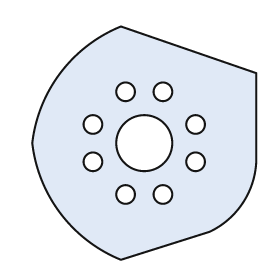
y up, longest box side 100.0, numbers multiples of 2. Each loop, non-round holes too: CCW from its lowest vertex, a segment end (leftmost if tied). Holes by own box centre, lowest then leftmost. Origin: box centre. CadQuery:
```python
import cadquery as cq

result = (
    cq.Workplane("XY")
    .moveTo(-10.0, -50.0)
    .lineTo(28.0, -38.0)
    .threePointArc((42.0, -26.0), (48.0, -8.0))
    .lineTo(48.0, 30.0)
    .lineTo(-10.0, 50.0)
    .threePointArc((-36.0, 30.0), (-48.0, 0.0))
    .threePointArc((-36.0, -30.0), (-10.0, -50.0))
    .close()
    .moveTo(-8.0, -22.0)
    .circle(4.0)
    .moveTo(8.0, -22.0)
    .circle(4.0)
    .moveTo(-22.0, -8.0)
    .circle(4.0)
    .moveTo(22.0, -8.0)
    .circle(4.0)
    .moveTo(0.0, 0.0)
    .circle(12.0)
    .moveTo(-22.0, 8.0)
    .circle(4.0)
    .moveTo(22.0, 8.0)
    .circle(4.0)
    .moveTo(-8.0, 22.0)
    .circle(4.0)
    .moveTo(8.0, 22.0)
    .circle(4.0)
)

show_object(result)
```